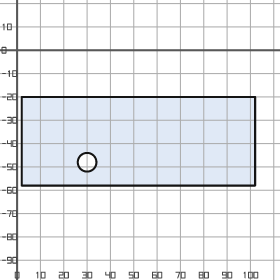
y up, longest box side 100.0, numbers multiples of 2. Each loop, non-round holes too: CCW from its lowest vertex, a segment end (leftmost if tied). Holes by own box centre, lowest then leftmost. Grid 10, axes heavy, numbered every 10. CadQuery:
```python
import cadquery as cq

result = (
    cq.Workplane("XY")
    .moveTo(2.0, -58.0)
    .lineTo(102.0, -58.0)
    .lineTo(102.0, -20.0)
    .lineTo(2.0, -20.0)
    .close()
    .moveTo(30.0, -48.0)
    .circle(4.0)
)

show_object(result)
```